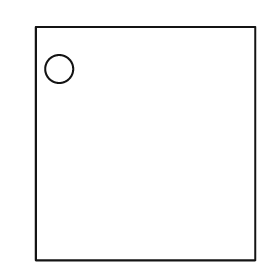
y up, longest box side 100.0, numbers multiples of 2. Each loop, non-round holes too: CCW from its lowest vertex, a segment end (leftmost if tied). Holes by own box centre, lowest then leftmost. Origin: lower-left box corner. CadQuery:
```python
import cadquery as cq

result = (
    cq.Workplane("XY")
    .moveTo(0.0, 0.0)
    .lineTo(94.0, 0.0)
    .lineTo(94.0, 100.0)
    .lineTo(0.0, 100.0)
    .close()
    .moveTo(10.0, 82.0)
    .circle(6.0)
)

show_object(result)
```